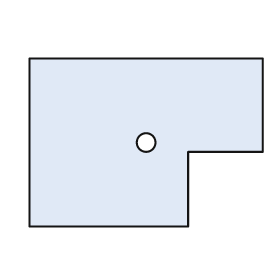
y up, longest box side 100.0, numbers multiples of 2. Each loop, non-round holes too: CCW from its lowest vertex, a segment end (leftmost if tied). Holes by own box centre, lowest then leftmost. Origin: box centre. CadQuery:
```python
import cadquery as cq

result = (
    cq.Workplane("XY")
    .moveTo(-50.0, -36.0)
    .lineTo(18.0, -36.0)
    .lineTo(18.0, -4.0)
    .lineTo(50.0, -4.0)
    .lineTo(50.0, 36.0)
    .lineTo(-50.0, 36.0)
    .close()
    .moveTo(0.0, 0.0)
    .circle(4.0)
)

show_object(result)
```